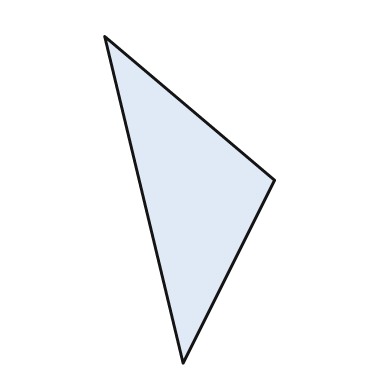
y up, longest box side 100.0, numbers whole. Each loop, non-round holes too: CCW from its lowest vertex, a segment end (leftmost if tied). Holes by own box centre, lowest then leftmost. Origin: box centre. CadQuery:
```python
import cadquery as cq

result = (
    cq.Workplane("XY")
    .moveTo(-2.0, -50.0)
    .lineTo(26.0, 6.0)
    .lineTo(-26.0, 50.0)
    .close()
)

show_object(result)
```